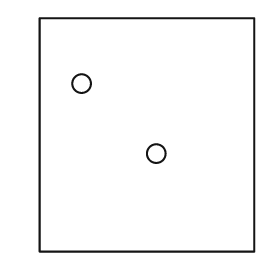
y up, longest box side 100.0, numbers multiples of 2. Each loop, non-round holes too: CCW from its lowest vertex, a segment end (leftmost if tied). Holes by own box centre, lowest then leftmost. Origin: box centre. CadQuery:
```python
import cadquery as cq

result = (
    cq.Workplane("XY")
    .moveTo(-46.0, -50.0)
    .lineTo(46.0, -50.0)
    .lineTo(46.0, 50.0)
    .lineTo(-46.0, 50.0)
    .close()
    .moveTo(4.0, -8.0)
    .circle(4.0)
    .moveTo(-28.0, 22.0)
    .circle(4.0)
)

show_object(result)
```